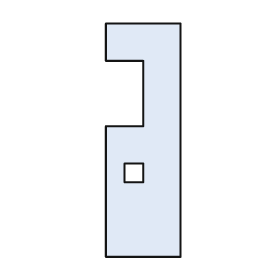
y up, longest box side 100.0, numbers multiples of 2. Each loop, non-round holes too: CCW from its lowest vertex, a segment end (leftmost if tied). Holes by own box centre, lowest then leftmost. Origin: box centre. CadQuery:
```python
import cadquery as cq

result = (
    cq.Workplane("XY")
    .moveTo(-16.0, -50.0)
    .lineTo(16.0, -50.0)
    .lineTo(16.0, 50.0)
    .lineTo(-16.0, 50.0)
    .lineTo(-16.0, 34.0)
    .lineTo(0.0, 34.0)
    .lineTo(0.0, 6.0)
    .lineTo(-16.0, 6.0)
    .close()
    .moveTo(-8.0, -18.0)
    .lineTo(0.0, -18.0)
    .lineTo(0.0, -10.0)
    .lineTo(-8.0, -10.0)
    .close()
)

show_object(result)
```